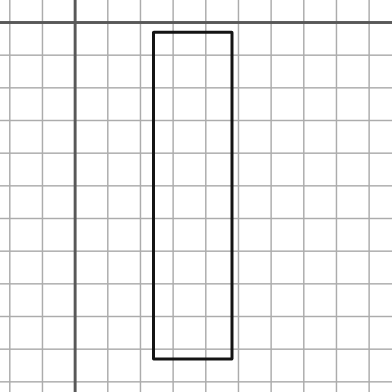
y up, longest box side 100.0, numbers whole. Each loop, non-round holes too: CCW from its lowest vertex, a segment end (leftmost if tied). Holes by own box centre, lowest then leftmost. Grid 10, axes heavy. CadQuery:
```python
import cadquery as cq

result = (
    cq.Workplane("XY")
    .moveTo(24.0, -103.0)
    .lineTo(48.0, -103.0)
    .lineTo(48.0, -3.0)
    .lineTo(24.0, -3.0)
    .close()
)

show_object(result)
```